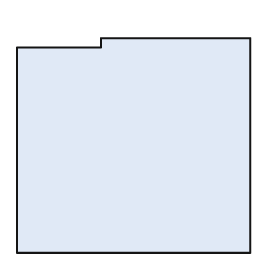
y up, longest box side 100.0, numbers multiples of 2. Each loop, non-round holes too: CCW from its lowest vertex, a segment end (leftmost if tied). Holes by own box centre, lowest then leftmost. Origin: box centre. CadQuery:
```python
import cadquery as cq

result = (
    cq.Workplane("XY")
    .moveTo(-50.0, -46.0)
    .lineTo(50.0, -46.0)
    .lineTo(50.0, 46.0)
    .lineTo(-14.0, 46.0)
    .lineTo(-14.0, 42.0)
    .lineTo(-50.0, 42.0)
    .close()
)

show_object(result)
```